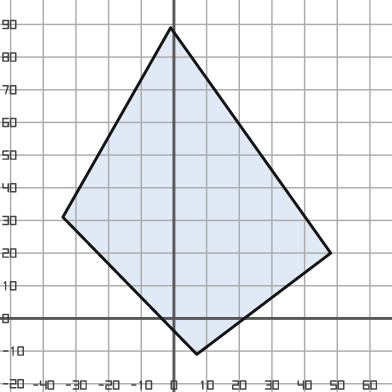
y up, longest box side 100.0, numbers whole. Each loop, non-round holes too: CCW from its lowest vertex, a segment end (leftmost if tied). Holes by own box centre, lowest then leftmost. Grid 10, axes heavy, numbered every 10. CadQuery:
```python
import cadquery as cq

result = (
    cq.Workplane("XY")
    .moveTo(7.0, -11.0)
    .lineTo(48.0, 20.0)
    .lineTo(-1.0, 89.0)
    .lineTo(-34.0, 31.0)
    .close()
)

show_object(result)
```